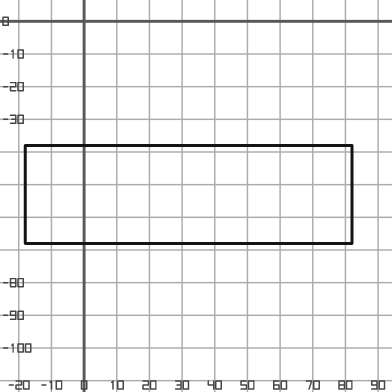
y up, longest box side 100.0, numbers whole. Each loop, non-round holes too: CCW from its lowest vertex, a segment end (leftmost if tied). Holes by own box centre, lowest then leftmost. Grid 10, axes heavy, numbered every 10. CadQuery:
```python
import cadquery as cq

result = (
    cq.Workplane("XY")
    .moveTo(-18.0, -68.0)
    .lineTo(82.0, -68.0)
    .lineTo(82.0, -38.0)
    .lineTo(-18.0, -38.0)
    .close()
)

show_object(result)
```